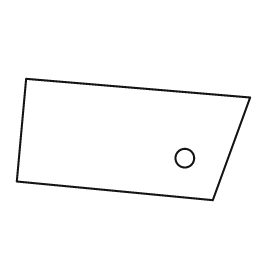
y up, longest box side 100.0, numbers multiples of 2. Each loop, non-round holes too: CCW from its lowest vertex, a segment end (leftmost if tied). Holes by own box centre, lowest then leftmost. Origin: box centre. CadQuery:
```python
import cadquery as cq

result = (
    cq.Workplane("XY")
    .moveTo(34.0, -26.0)
    .lineTo(50.0, 18.0)
    .lineTo(-46.0, 26.0)
    .lineTo(-50.0, -18.0)
    .close()
    .moveTo(22.0, -8.0)
    .circle(4.0)
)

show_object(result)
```